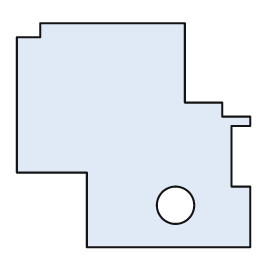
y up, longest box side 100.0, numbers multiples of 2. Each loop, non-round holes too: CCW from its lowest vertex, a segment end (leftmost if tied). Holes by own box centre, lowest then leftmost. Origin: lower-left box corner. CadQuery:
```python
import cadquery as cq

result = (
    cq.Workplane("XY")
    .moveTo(30.0, 0.0)
    .lineTo(100.0, 0.0)
    .lineTo(100.0, 26.0)
    .lineTo(92.0, 26.0)
    .lineTo(92.0, 52.0)
    .lineTo(100.0, 52.0)
    .lineTo(100.0, 56.0)
    .lineTo(88.0, 56.0)
    .lineTo(88.0, 62.0)
    .lineTo(72.0, 62.0)
    .lineTo(72.0, 96.0)
    .lineTo(10.0, 96.0)
    .lineTo(10.0, 90.0)
    .lineTo(0.0, 90.0)
    .lineTo(0.0, 32.0)
    .lineTo(30.0, 32.0)
    .close()
    .moveTo(68.0, 18.0)
    .circle(8.0)
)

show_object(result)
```